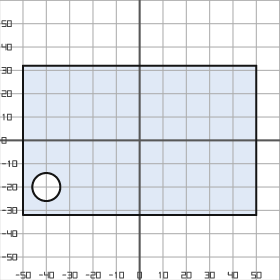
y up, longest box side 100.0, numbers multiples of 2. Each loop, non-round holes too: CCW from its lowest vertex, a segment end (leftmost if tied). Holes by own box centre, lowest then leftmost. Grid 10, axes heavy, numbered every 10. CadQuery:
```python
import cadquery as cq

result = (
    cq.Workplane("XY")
    .moveTo(-50.0, -32.0)
    .lineTo(50.0, -32.0)
    .lineTo(50.0, 32.0)
    .lineTo(-50.0, 32.0)
    .close()
    .moveTo(-40.0, -20.0)
    .circle(6.0)
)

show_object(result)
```